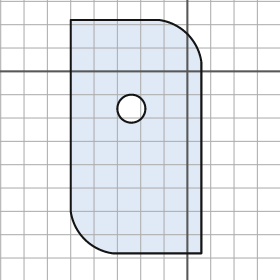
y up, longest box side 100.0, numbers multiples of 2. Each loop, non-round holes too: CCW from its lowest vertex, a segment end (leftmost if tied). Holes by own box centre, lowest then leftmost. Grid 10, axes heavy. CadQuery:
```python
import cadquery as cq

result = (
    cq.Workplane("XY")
    .moveTo(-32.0, -78.0)
    .lineTo(6.0, -78.0)
    .lineTo(6.0, 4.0)
    .threePointArc((0.0, 16.0), (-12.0, 22.0))
    .lineTo(-50.0, 22.0)
    .lineTo(-50.0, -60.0)
    .threePointArc((-44.0, -72.0), (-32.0, -78.0))
    .close()
    .moveTo(-24.0, -16.0)
    .circle(6.0)
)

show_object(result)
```